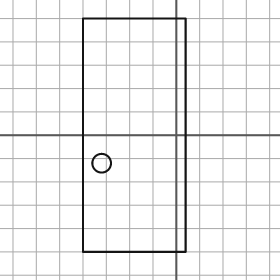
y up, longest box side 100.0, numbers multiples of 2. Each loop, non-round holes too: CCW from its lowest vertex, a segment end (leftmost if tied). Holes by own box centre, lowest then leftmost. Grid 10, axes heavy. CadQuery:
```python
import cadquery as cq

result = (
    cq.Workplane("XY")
    .moveTo(-40.0, -50.0)
    .lineTo(4.0, -50.0)
    .lineTo(4.0, 50.0)
    .lineTo(-40.0, 50.0)
    .close()
    .moveTo(-32.0, -12.0)
    .circle(4.0)
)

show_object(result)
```